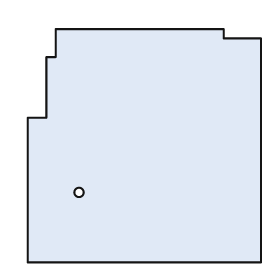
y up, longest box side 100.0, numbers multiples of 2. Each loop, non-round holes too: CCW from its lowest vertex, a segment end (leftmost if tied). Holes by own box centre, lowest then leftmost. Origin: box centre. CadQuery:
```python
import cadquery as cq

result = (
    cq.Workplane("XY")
    .moveTo(-50.0, -50.0)
    .lineTo(50.0, -50.0)
    .lineTo(50.0, 46.0)
    .lineTo(34.0, 46.0)
    .lineTo(34.0, 50.0)
    .lineTo(-38.0, 50.0)
    .lineTo(-38.0, 38.0)
    .lineTo(-42.0, 38.0)
    .lineTo(-42.0, 12.0)
    .lineTo(-50.0, 12.0)
    .close()
    .moveTo(-28.0, -20.0)
    .circle(2.0)
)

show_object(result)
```